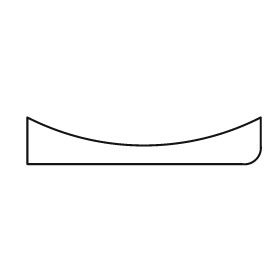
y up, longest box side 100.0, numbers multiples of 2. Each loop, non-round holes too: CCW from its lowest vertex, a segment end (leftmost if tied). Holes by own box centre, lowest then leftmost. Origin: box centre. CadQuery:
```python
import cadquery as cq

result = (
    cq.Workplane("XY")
    .moveTo(-50.0, -10.0)
    .lineTo(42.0, -10.0)
    .threePointArc((48.0, -8.0), (50.0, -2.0))
    .lineTo(50.0, 10.0)
    .threePointArc((0.0, -2.0), (-50.0, 10.0))
    .close()
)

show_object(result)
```